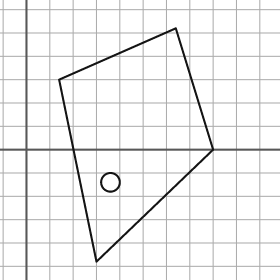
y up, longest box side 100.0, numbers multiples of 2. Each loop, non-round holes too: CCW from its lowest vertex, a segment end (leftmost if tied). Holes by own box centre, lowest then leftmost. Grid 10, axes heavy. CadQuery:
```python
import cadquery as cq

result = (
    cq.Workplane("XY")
    .moveTo(30.0, -48.0)
    .lineTo(80.0, 0.0)
    .lineTo(64.0, 52.0)
    .lineTo(14.0, 30.0)
    .close()
    .moveTo(36.0, -14.0)
    .circle(4.0)
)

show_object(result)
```